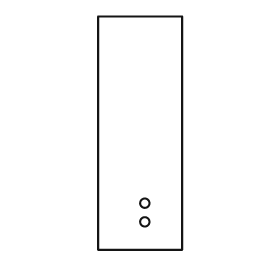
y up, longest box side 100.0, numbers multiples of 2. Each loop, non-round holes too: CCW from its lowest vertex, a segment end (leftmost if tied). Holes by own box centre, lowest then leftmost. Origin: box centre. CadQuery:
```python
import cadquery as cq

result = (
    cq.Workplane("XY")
    .moveTo(-18.0, -50.0)
    .lineTo(18.0, -50.0)
    .lineTo(18.0, 50.0)
    .lineTo(-18.0, 50.0)
    .close()
    .moveTo(2.0, -38.0)
    .circle(2.0)
    .moveTo(2.0, -30.0)
    .circle(2.0)
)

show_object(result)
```